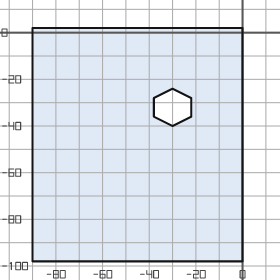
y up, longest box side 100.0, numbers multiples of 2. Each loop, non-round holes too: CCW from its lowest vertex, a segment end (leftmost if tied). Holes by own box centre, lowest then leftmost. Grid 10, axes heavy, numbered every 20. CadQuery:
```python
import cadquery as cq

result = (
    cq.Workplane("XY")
    .moveTo(-90.0, -98.0)
    .lineTo(0.0, -98.0)
    .lineTo(0.0, 2.0)
    .lineTo(-90.0, 2.0)
    .close()
    .moveTo(-30.0, -40.0)
    .lineTo(-22.0, -36.0)
    .lineTo(-22.0, -28.0)
    .lineTo(-30.0, -24.0)
    .lineTo(-38.0, -28.0)
    .lineTo(-38.0, -36.0)
    .close()
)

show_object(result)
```